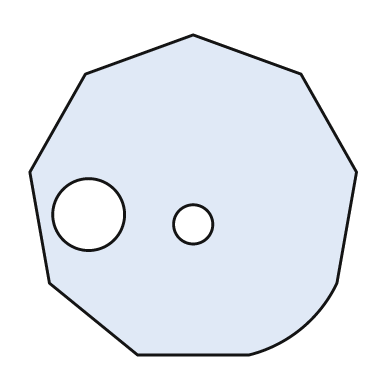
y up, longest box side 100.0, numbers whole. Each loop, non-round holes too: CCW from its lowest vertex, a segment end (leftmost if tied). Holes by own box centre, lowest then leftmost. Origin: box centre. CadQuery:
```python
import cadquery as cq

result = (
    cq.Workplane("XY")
    .moveTo(-17.0, -49.0)
    .lineTo(17.0, -49.0)
    .threePointArc((33.0, -41.0), (44.0, -27.0))
    .lineTo(50.0, 7.0)
    .lineTo(33.0, 37.0)
    .lineTo(0.0, 49.0)
    .lineTo(-33.0, 37.0)
    .lineTo(-50.0, 7.0)
    .lineTo(-44.0, -27.0)
    .close()
    .moveTo(0.0, -9.0)
    .circle(6.0)
    .moveTo(-32.0, -6.0)
    .circle(11.0)
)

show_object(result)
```